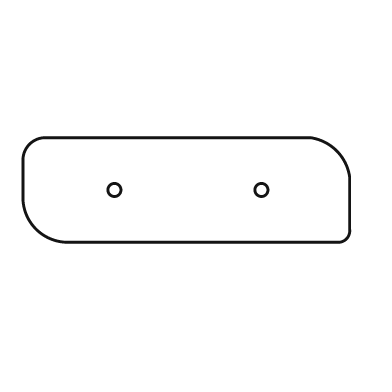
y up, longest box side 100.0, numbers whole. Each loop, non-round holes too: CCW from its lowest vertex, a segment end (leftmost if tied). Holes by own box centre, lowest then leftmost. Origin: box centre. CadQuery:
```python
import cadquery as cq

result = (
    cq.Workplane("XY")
    .moveTo(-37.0, -16.0)
    .lineTo(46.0, -16.0)
    .threePointArc((49.0, -15.0), (50.0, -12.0))
    .lineTo(50.0, 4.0)
    .threePointArc((46.0, 12.0), (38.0, 16.0))
    .lineTo(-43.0, 16.0)
    .threePointArc((-48.0, 14.0), (-50.0, 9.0))
    .lineTo(-50.0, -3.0)
    .threePointArc((-46.0, -12.0), (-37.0, -16.0))
    .close()
    .moveTo(-22.0, 0.0)
    .circle(2.0)
    .moveTo(23.0, 0.0)
    .circle(2.0)
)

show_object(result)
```